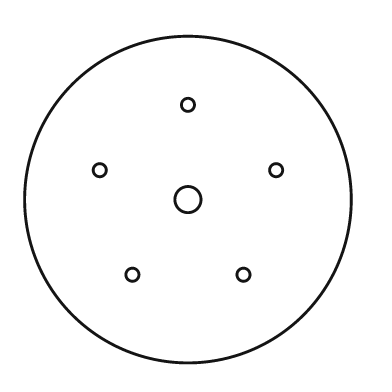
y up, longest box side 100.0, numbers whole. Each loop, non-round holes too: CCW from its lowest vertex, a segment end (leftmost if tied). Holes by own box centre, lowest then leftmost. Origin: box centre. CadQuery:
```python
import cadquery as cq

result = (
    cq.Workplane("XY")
    .moveTo(0.0, 0.0)
    .circle(50.0)
    .moveTo(-17.0, -23.0)
    .circle(2.0)
    .moveTo(17.0, -23.0)
    .circle(2.0)
    .moveTo(0.0, 0.0)
    .circle(4.0)
    .moveTo(-27.0, 9.0)
    .circle(2.0)
    .moveTo(27.0, 9.0)
    .circle(2.0)
    .moveTo(0.0, 29.0)
    .circle(2.0)
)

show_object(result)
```